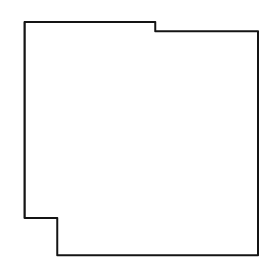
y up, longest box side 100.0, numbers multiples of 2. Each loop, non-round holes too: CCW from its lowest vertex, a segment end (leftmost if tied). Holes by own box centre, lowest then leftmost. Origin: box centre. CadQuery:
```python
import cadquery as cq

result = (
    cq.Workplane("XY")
    .moveTo(-36.0, -50.0)
    .lineTo(50.0, -50.0)
    .lineTo(50.0, 46.0)
    .lineTo(6.0, 46.0)
    .lineTo(6.0, 50.0)
    .lineTo(-50.0, 50.0)
    .lineTo(-50.0, -34.0)
    .lineTo(-36.0, -34.0)
    .close()
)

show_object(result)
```